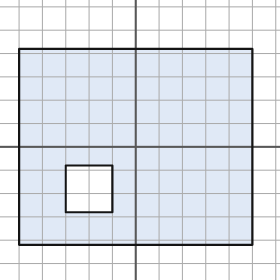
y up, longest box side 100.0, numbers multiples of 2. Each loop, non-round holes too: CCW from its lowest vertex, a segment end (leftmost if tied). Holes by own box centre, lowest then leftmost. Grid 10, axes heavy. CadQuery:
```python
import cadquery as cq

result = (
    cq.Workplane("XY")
    .moveTo(-50.0, -42.0)
    .lineTo(50.0, -42.0)
    .lineTo(50.0, 42.0)
    .lineTo(-50.0, 42.0)
    .close()
    .moveTo(-30.0, -28.0)
    .lineTo(-10.0, -28.0)
    .lineTo(-10.0, -8.0)
    .lineTo(-30.0, -8.0)
    .close()
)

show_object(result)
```